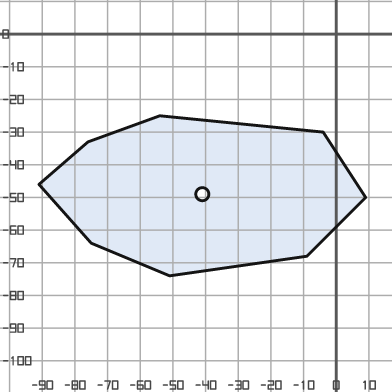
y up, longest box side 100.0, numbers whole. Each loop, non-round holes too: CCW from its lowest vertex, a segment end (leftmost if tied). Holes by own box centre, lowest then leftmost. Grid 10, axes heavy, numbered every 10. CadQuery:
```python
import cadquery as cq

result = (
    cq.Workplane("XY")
    .moveTo(-51.0, -74.0)
    .lineTo(-9.0, -68.0)
    .lineTo(9.0, -50.0)
    .lineTo(-4.0, -30.0)
    .lineTo(-54.0, -25.0)
    .lineTo(-76.0, -33.0)
    .lineTo(-91.0, -46.0)
    .lineTo(-75.0, -64.0)
    .close()
    .moveTo(-41.0, -49.0)
    .circle(2.0)
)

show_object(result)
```